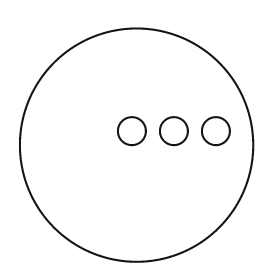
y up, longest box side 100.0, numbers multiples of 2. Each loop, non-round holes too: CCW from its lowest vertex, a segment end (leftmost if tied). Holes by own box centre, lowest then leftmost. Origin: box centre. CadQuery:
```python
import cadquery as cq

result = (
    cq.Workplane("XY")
    .moveTo(0.0, 0.0)
    .circle(50.0)
    .moveTo(-2.0, 6.0)
    .circle(6.0)
    .moveTo(16.0, 6.0)
    .circle(6.0)
    .moveTo(34.0, 6.0)
    .circle(6.0)
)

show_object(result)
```